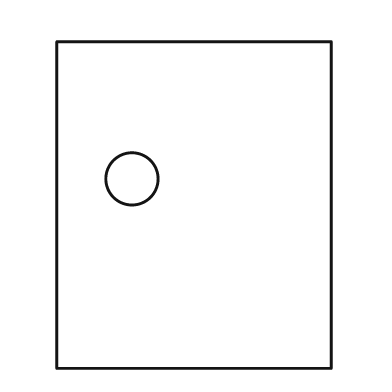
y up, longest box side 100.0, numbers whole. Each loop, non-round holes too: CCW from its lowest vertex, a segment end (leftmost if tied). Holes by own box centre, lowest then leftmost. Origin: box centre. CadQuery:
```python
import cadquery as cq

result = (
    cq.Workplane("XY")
    .moveTo(-42.0, -50.0)
    .lineTo(42.0, -50.0)
    .lineTo(42.0, 50.0)
    .lineTo(-42.0, 50.0)
    .close()
    .moveTo(-19.0, 8.0)
    .circle(8.0)
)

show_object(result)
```